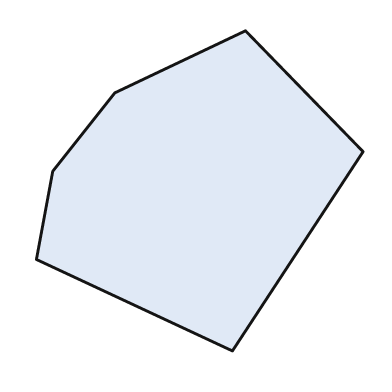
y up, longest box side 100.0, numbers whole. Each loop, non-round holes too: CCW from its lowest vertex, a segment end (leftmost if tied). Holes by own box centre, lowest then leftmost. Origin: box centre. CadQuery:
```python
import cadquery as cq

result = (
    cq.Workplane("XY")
    .moveTo(10.0, -49.0)
    .lineTo(50.0, 12.0)
    .lineTo(14.0, 49.0)
    .lineTo(-26.0, 30.0)
    .lineTo(-45.0, 6.0)
    .lineTo(-50.0, -21.0)
    .close()
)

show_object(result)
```